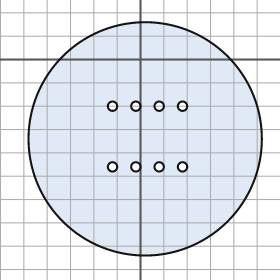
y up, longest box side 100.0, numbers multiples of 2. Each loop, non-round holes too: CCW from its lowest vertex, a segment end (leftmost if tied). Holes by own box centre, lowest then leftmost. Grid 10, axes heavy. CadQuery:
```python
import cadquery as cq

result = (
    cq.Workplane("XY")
    .moveTo(2.0, -34.0)
    .circle(50.0)
    .moveTo(-12.0, -46.0)
    .circle(2.0)
    .moveTo(-2.0, -46.0)
    .circle(2.0)
    .moveTo(8.0, -46.0)
    .circle(2.0)
    .moveTo(18.0, -46.0)
    .circle(2.0)
    .moveTo(-12.0, -20.0)
    .circle(2.0)
    .moveTo(-2.0, -20.0)
    .circle(2.0)
    .moveTo(8.0, -20.0)
    .circle(2.0)
    .moveTo(18.0, -20.0)
    .circle(2.0)
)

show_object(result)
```